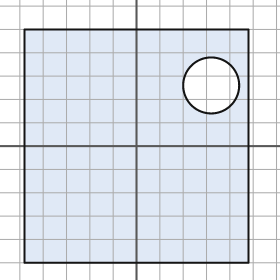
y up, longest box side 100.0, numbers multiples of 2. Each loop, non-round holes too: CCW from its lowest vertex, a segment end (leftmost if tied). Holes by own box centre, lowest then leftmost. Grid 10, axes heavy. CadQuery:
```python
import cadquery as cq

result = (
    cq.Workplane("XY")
    .moveTo(-48.0, -50.0)
    .lineTo(48.0, -50.0)
    .lineTo(48.0, 50.0)
    .lineTo(-48.0, 50.0)
    .close()
    .moveTo(32.0, 26.0)
    .circle(12.0)
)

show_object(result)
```